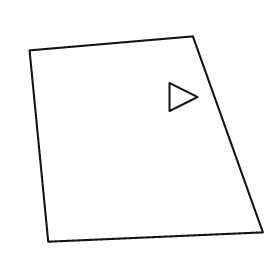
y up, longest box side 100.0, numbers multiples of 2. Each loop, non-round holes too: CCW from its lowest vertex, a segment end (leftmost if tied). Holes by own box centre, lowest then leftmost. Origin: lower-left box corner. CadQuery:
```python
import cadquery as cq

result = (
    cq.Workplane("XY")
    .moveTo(8.0, 0.0)
    .lineTo(100.0, 4.0)
    .lineTo(70.0, 88.0)
    .lineTo(0.0, 82.0)
    .close()
    .moveTo(60.0, 56.0)
    .lineTo(72.0, 62.0)
    .lineTo(60.0, 68.0)
    .close()
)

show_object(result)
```